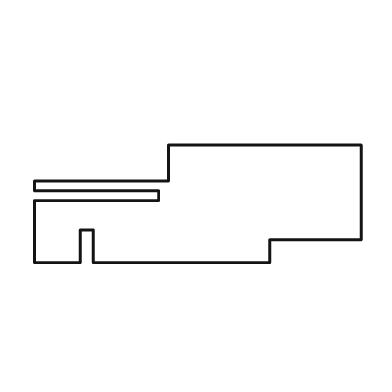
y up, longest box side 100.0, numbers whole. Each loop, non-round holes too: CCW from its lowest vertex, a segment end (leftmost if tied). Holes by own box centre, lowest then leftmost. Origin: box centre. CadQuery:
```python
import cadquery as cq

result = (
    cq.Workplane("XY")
    .moveTo(-50.0, -18.0)
    .lineTo(-36.0, -18.0)
    .lineTo(-36.0, -8.0)
    .lineTo(-32.0, -8.0)
    .lineTo(-32.0, -18.0)
    .lineTo(22.0, -18.0)
    .lineTo(22.0, -11.0)
    .lineTo(50.0, -11.0)
    .lineTo(50.0, 18.0)
    .lineTo(-9.0, 18.0)
    .lineTo(-9.0, 7.0)
    .lineTo(-50.0, 7.0)
    .lineTo(-50.0, 4.0)
    .lineTo(-12.0, 4.0)
    .lineTo(-12.0, 1.0)
    .lineTo(-50.0, 1.0)
    .close()
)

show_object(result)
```